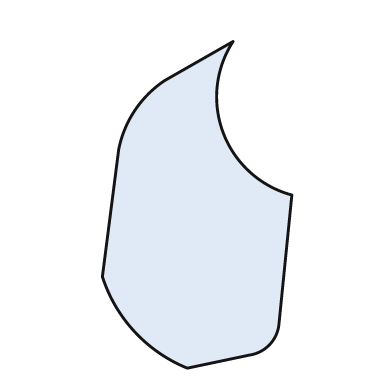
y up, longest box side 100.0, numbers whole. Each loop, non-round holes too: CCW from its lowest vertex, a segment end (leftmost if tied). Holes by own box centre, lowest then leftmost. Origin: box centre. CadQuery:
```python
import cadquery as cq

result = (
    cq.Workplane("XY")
    .moveTo(-3.0, -50.0)
    .lineTo(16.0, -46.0)
    .threePointArc((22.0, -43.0), (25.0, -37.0))
    .lineTo(29.0, 3.0)
    .threePointArc((8.0, 22.0), (11.0, 50.0))
    .lineTo(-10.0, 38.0)
    .threePointArc((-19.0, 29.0), (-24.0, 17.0))
    .lineTo(-29.0, -22.0)
    .threePointArc((-19.0, -39.0), (-3.0, -50.0))
    .close()
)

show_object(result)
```